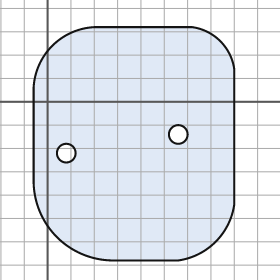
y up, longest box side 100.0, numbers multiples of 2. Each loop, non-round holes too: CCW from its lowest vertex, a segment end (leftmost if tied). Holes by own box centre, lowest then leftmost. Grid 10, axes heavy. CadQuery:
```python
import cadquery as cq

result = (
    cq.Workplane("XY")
    .moveTo(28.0, -68.0)
    .lineTo(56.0, -68.0)
    .threePointArc((72.0, -60.0), (80.0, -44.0))
    .lineTo(80.0, 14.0)
    .threePointArc((74.0, 26.0), (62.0, 32.0))
    .lineTo(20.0, 32.0)
    .threePointArc((2.0, 24.0), (-6.0, 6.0))
    .lineTo(-6.0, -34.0)
    .threePointArc((4.0, -58.0), (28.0, -68.0))
    .close()
    .moveTo(8.0, -22.0)
    .circle(4.0)
    .moveTo(56.0, -14.0)
    .circle(4.0)
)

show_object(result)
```